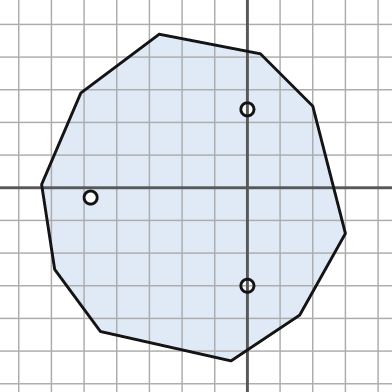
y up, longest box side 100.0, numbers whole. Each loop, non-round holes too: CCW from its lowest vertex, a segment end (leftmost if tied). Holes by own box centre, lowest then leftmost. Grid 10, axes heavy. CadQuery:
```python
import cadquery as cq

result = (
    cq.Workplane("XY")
    .moveTo(-5.0, -53.0)
    .lineTo(16.0, -39.0)
    .lineTo(30.0, -14.0)
    .lineTo(20.0, 25.0)
    .lineTo(4.0, 41.0)
    .lineTo(-27.0, 47.0)
    .lineTo(-51.0, 29.0)
    .lineTo(-63.0, 1.0)
    .lineTo(-59.0, -25.0)
    .lineTo(-45.0, -44.0)
    .close()
    .moveTo(0.0, -30.0)
    .circle(2.0)
    .moveTo(-48.0, -3.0)
    .circle(2.0)
    .moveTo(0.0, 24.0)
    .circle(2.0)
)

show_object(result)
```